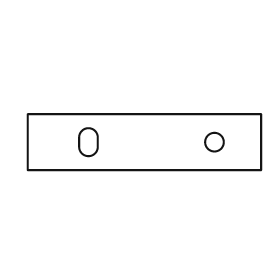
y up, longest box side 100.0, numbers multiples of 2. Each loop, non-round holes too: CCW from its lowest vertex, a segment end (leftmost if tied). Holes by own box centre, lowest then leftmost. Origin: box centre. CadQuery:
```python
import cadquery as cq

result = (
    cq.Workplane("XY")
    .moveTo(-50.0, -12.0)
    .lineTo(50.0, -12.0)
    .lineTo(50.0, 12.0)
    .lineTo(-50.0, 12.0)
    .close()
    .moveTo(-28.0, -2.0)
    .threePointArc((-24.0, -6.0), (-20.0, -2.0))
    .lineTo(-20.0, 2.0)
    .threePointArc((-24.0, 6.0), (-28.0, 2.0))
    .close()
    .moveTo(30.0, 0.0)
    .circle(4.0)
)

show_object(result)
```